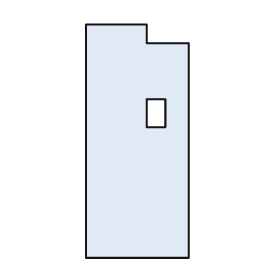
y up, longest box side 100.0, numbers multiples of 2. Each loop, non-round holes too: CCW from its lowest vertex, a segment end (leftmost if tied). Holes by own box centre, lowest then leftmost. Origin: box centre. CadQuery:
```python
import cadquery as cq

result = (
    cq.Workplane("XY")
    .moveTo(-22.0, -50.0)
    .lineTo(22.0, -50.0)
    .lineTo(22.0, 42.0)
    .lineTo(4.0, 42.0)
    .lineTo(4.0, 50.0)
    .lineTo(-22.0, 50.0)
    .close()
    .moveTo(4.0, 6.0)
    .lineTo(12.0, 6.0)
    .lineTo(12.0, 18.0)
    .lineTo(4.0, 18.0)
    .close()
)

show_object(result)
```